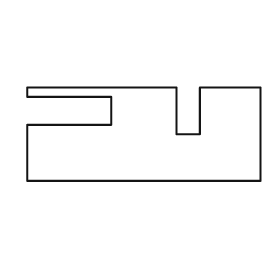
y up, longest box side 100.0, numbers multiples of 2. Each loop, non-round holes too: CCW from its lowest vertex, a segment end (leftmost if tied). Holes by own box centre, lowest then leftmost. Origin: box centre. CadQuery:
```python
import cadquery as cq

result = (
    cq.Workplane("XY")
    .moveTo(-50.0, -20.0)
    .lineTo(50.0, -20.0)
    .lineTo(50.0, 20.0)
    .lineTo(24.0, 20.0)
    .lineTo(24.0, 0.0)
    .lineTo(14.0, 0.0)
    .lineTo(14.0, 20.0)
    .lineTo(-50.0, 20.0)
    .lineTo(-50.0, 16.0)
    .lineTo(-14.0, 16.0)
    .lineTo(-14.0, 4.0)
    .lineTo(-50.0, 4.0)
    .close()
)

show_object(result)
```